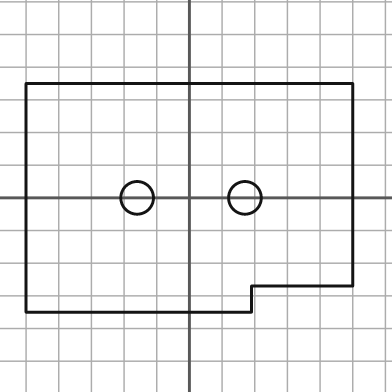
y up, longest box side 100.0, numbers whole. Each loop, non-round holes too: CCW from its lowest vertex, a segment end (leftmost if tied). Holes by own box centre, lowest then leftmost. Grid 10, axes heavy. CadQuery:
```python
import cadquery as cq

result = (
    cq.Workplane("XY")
    .moveTo(-50.0, -35.0)
    .lineTo(19.0, -35.0)
    .lineTo(19.0, -27.0)
    .lineTo(50.0, -27.0)
    .lineTo(50.0, 35.0)
    .lineTo(-50.0, 35.0)
    .close()
    .moveTo(-16.0, 0.0)
    .circle(5.0)
    .moveTo(17.0, 0.0)
    .circle(5.0)
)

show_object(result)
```